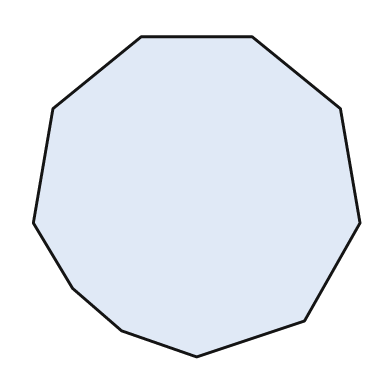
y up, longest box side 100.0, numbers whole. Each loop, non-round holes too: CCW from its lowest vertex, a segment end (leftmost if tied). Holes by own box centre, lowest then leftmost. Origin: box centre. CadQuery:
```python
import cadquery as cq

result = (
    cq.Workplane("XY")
    .moveTo(0.0, -49.0)
    .lineTo(33.0, -38.0)
    .lineTo(50.0, -8.0)
    .lineTo(44.0, 27.0)
    .lineTo(17.0, 49.0)
    .lineTo(-17.0, 49.0)
    .lineTo(-44.0, 27.0)
    .lineTo(-50.0, -8.0)
    .lineTo(-38.0, -28.0)
    .lineTo(-23.0, -41.0)
    .close()
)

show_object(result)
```